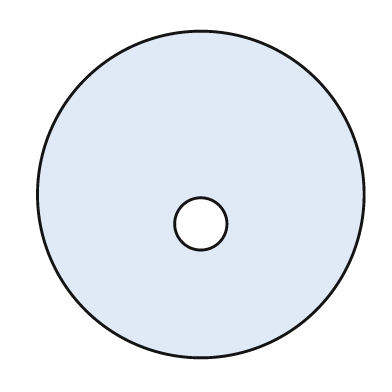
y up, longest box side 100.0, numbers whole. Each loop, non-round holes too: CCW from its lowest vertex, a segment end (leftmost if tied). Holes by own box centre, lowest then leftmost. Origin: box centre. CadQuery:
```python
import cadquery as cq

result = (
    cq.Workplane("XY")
    .moveTo(0.0, 0.0)
    .circle(50.0)
    .moveTo(0.0, -9.0)
    .circle(8.0)
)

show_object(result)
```